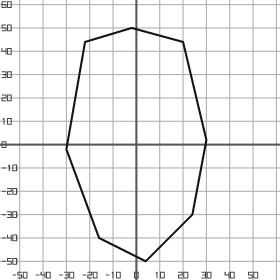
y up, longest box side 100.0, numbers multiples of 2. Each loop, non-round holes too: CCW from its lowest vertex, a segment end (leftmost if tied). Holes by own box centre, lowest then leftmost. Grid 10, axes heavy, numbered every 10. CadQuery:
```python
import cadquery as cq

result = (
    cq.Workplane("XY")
    .moveTo(4.0, -50.0)
    .lineTo(24.0, -30.0)
    .lineTo(30.0, 2.0)
    .lineTo(20.0, 44.0)
    .lineTo(-2.0, 50.0)
    .lineTo(-22.0, 44.0)
    .lineTo(-30.0, -2.0)
    .lineTo(-16.0, -40.0)
    .close()
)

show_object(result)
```